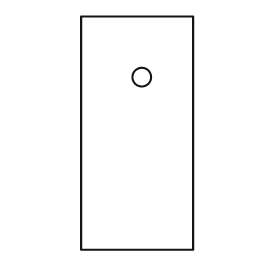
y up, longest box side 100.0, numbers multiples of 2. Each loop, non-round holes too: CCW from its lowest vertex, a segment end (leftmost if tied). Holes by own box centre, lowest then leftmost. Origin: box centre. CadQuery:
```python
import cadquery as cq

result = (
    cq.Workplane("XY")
    .moveTo(-24.0, -50.0)
    .lineTo(24.0, -50.0)
    .lineTo(24.0, 50.0)
    .lineTo(-24.0, 50.0)
    .close()
    .moveTo(2.0, 24.0)
    .circle(4.0)
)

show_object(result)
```